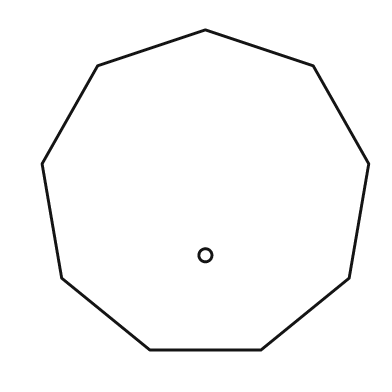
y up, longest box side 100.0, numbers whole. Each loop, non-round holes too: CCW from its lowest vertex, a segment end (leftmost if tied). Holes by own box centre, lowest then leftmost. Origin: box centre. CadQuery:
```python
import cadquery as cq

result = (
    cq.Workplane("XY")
    .moveTo(-17.0, -49.0)
    .lineTo(17.0, -49.0)
    .lineTo(44.0, -27.0)
    .lineTo(50.0, 8.0)
    .lineTo(33.0, 38.0)
    .lineTo(0.0, 49.0)
    .lineTo(-33.0, 38.0)
    .lineTo(-50.0, 8.0)
    .lineTo(-44.0, -27.0)
    .close()
    .moveTo(0.0, -20.0)
    .circle(2.0)
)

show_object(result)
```